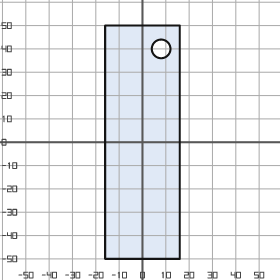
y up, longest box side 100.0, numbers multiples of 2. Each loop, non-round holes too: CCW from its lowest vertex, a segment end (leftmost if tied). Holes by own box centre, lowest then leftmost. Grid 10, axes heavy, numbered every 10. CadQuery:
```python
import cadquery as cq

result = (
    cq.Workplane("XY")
    .moveTo(-16.0, -50.0)
    .lineTo(16.0, -50.0)
    .lineTo(16.0, 50.0)
    .lineTo(-16.0, 50.0)
    .close()
    .moveTo(8.0, 40.0)
    .circle(4.0)
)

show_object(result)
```